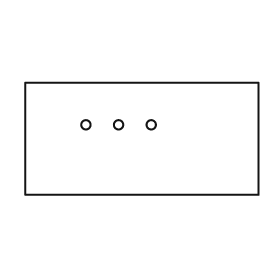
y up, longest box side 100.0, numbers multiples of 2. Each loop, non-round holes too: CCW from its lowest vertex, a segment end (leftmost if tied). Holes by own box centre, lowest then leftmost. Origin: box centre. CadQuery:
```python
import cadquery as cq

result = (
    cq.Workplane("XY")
    .moveTo(-50.0, -24.0)
    .lineTo(50.0, -24.0)
    .lineTo(50.0, 24.0)
    .lineTo(-50.0, 24.0)
    .close()
    .moveTo(-24.0, 6.0)
    .circle(2.0)
    .moveTo(-10.0, 6.0)
    .circle(2.0)
    .moveTo(4.0, 6.0)
    .circle(2.0)
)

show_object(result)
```